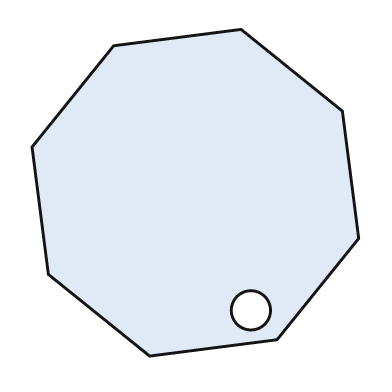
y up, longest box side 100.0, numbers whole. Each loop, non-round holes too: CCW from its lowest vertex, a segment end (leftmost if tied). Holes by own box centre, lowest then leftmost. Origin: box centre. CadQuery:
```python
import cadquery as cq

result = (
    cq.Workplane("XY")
    .moveTo(-14.0, -50.0)
    .lineTo(25.0, -45.0)
    .lineTo(50.0, -14.0)
    .lineTo(45.0, 25.0)
    .lineTo(14.0, 50.0)
    .lineTo(-25.0, 45.0)
    .lineTo(-50.0, 14.0)
    .lineTo(-45.0, -25.0)
    .close()
    .moveTo(17.0, -36.0)
    .circle(6.0)
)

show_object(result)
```